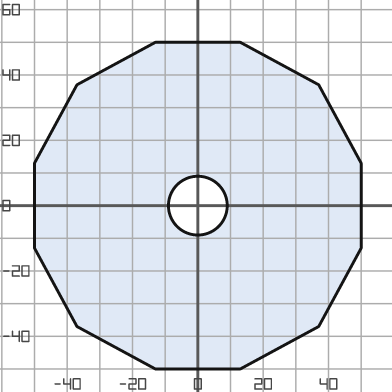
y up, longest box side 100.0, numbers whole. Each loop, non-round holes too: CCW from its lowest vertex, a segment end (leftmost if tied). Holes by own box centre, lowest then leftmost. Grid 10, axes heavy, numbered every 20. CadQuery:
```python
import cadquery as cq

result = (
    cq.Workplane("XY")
    .moveTo(-13.0, -50.0)
    .lineTo(13.0, -50.0)
    .lineTo(37.0, -37.0)
    .lineTo(50.0, -13.0)
    .lineTo(50.0, 13.0)
    .lineTo(37.0, 37.0)
    .lineTo(13.0, 50.0)
    .lineTo(-13.0, 50.0)
    .lineTo(-37.0, 37.0)
    .lineTo(-50.0, 13.0)
    .lineTo(-50.0, -13.0)
    .lineTo(-37.0, -37.0)
    .close()
    .moveTo(0.0, 0.0)
    .circle(9.0)
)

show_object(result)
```